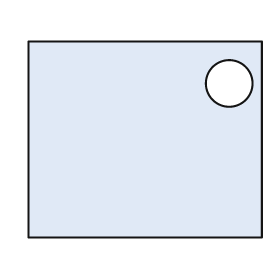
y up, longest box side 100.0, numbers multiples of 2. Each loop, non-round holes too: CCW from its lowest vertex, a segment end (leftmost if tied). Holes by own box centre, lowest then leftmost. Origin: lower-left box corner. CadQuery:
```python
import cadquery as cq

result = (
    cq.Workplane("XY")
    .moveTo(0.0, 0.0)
    .lineTo(100.0, 0.0)
    .lineTo(100.0, 84.0)
    .lineTo(0.0, 84.0)
    .close()
    .moveTo(86.0, 66.0)
    .circle(10.0)
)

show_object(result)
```